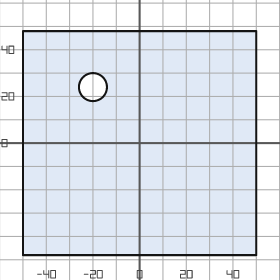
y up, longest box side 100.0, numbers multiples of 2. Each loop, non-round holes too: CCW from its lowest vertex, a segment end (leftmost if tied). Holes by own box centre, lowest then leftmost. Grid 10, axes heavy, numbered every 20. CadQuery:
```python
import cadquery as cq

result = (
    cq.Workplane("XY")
    .moveTo(-50.0, -48.0)
    .lineTo(50.0, -48.0)
    .lineTo(50.0, 48.0)
    .lineTo(-50.0, 48.0)
    .close()
    .moveTo(-20.0, 24.0)
    .circle(6.0)
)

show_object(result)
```